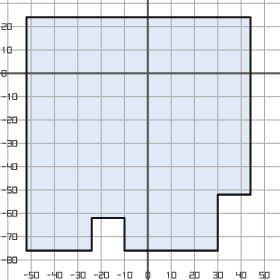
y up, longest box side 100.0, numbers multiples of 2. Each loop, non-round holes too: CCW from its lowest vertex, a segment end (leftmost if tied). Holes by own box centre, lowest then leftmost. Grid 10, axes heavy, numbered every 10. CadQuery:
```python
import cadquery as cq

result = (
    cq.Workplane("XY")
    .moveTo(-52.0, -76.0)
    .lineTo(-24.0, -76.0)
    .lineTo(-24.0, -62.0)
    .lineTo(-10.0, -62.0)
    .lineTo(-10.0, -76.0)
    .lineTo(30.0, -76.0)
    .lineTo(30.0, -52.0)
    .lineTo(44.0, -52.0)
    .lineTo(44.0, 24.0)
    .lineTo(-52.0, 24.0)
    .close()
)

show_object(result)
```